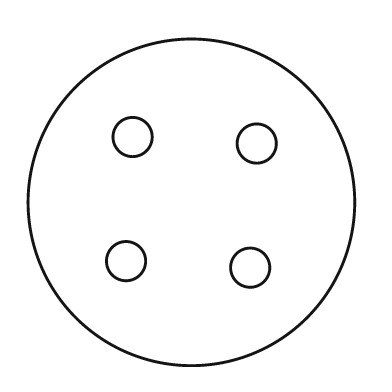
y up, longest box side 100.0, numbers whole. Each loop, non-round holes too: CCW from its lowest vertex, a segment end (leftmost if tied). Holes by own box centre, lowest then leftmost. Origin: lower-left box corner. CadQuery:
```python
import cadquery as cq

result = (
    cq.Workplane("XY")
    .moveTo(50.0, 50.0)
    .circle(50.0)
    .moveTo(68.0, 30.0)
    .circle(6.0)
    .moveTo(30.0, 32.0)
    .circle(6.0)
    .moveTo(70.0, 68.0)
    .circle(6.0)
    .moveTo(32.0, 70.0)
    .circle(6.0)
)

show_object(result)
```